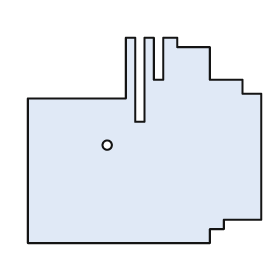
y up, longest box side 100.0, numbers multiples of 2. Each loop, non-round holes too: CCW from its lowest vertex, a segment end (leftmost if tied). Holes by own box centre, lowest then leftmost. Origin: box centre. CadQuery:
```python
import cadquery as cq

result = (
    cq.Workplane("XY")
    .moveTo(-50.0, -44.0)
    .lineTo(28.0, -44.0)
    .lineTo(28.0, -38.0)
    .lineTo(34.0, -38.0)
    .lineTo(34.0, -34.0)
    .lineTo(50.0, -34.0)
    .lineTo(50.0, 20.0)
    .lineTo(42.0, 20.0)
    .lineTo(42.0, 26.0)
    .lineTo(28.0, 26.0)
    .lineTo(28.0, 40.0)
    .lineTo(14.0, 40.0)
    .lineTo(14.0, 44.0)
    .lineTo(8.0, 44.0)
    .lineTo(8.0, 26.0)
    .lineTo(4.0, 26.0)
    .lineTo(4.0, 44.0)
    .lineTo(0.0, 44.0)
    .lineTo(0.0, 8.0)
    .lineTo(-4.0, 8.0)
    .lineTo(-4.0, 44.0)
    .lineTo(-8.0, 44.0)
    .lineTo(-8.0, 18.0)
    .lineTo(-50.0, 18.0)
    .close()
    .moveTo(-16.0, -2.0)
    .circle(2.0)
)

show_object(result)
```